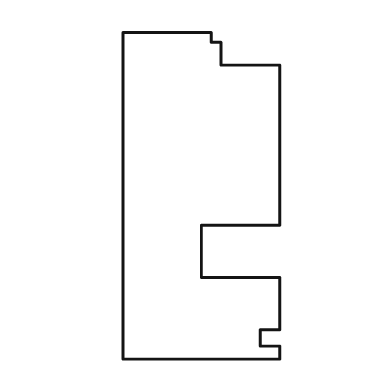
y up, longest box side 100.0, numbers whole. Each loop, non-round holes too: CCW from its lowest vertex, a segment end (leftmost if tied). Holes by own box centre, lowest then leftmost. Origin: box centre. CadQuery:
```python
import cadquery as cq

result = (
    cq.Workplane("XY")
    .moveTo(-24.0, -50.0)
    .lineTo(24.0, -50.0)
    .lineTo(24.0, -46.0)
    .lineTo(18.0, -46.0)
    .lineTo(18.0, -41.0)
    .lineTo(24.0, -41.0)
    .lineTo(24.0, -25.0)
    .lineTo(0.0, -25.0)
    .lineTo(0.0, -9.0)
    .lineTo(24.0, -9.0)
    .lineTo(24.0, 40.0)
    .lineTo(6.0, 40.0)
    .lineTo(6.0, 47.0)
    .lineTo(3.0, 47.0)
    .lineTo(3.0, 50.0)
    .lineTo(-24.0, 50.0)
    .close()
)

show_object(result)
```